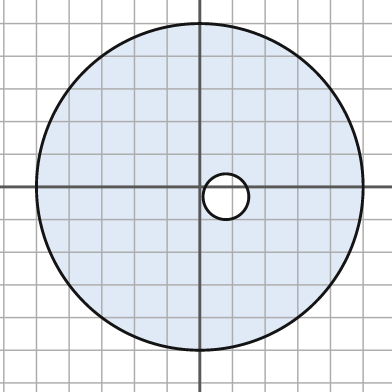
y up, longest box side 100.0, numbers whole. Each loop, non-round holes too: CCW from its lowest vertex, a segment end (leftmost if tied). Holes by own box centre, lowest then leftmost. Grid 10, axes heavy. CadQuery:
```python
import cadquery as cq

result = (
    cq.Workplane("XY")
    .moveTo(0.0, 0.0)
    .circle(50.0)
    .moveTo(8.0, -3.0)
    .circle(7.0)
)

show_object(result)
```